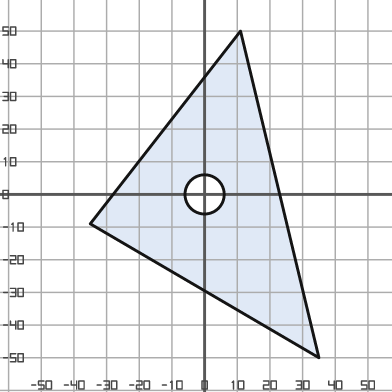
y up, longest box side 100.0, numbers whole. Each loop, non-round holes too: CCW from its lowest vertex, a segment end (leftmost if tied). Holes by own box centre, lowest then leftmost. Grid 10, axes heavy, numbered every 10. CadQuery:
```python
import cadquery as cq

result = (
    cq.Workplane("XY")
    .moveTo(35.0, -50.0)
    .lineTo(11.0, 50.0)
    .lineTo(-35.0, -9.0)
    .close()
    .moveTo(0.0, 0.0)
    .circle(6.0)
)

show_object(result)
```